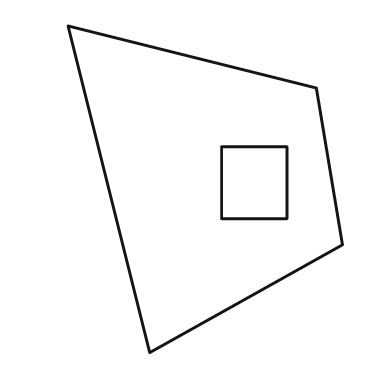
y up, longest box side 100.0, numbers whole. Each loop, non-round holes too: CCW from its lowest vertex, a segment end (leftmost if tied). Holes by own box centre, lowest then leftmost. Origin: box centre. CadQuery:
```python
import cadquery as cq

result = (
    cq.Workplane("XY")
    .moveTo(-17.0, -50.0)
    .lineTo(42.0, -17.0)
    .lineTo(34.0, 31.0)
    .lineTo(-42.0, 50.0)
    .close()
    .moveTo(5.0, -9.0)
    .lineTo(25.0, -9.0)
    .lineTo(25.0, 13.0)
    .lineTo(5.0, 13.0)
    .close()
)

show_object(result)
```